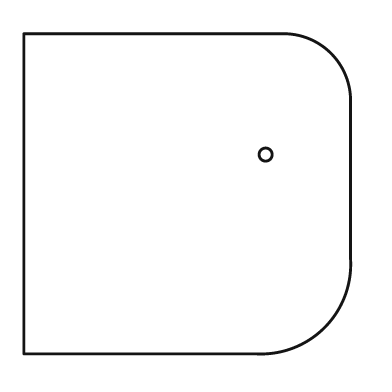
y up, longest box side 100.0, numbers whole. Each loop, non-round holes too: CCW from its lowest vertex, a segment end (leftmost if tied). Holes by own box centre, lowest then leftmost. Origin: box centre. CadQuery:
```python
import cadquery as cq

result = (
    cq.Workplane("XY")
    .moveTo(-50.0, -49.0)
    .lineTo(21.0, -49.0)
    .threePointArc((42.0, -41.0), (50.0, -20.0))
    .lineTo(50.0, 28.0)
    .threePointArc((44.0, 43.0), (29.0, 49.0))
    .lineTo(-50.0, 49.0)
    .close()
    .moveTo(24.0, 12.0)
    .circle(2.0)
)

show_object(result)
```